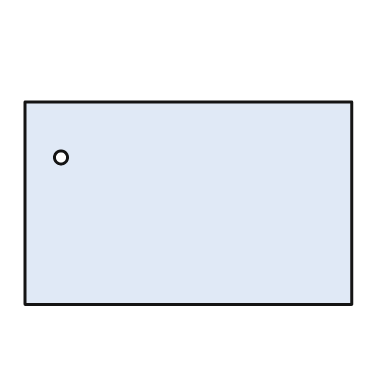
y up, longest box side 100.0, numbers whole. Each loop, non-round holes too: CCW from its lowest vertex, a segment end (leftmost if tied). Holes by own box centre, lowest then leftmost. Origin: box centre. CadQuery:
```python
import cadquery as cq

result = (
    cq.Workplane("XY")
    .moveTo(-50.0, -31.0)
    .lineTo(50.0, -31.0)
    .lineTo(50.0, 31.0)
    .lineTo(-50.0, 31.0)
    .close()
    .moveTo(-39.0, 14.0)
    .circle(2.0)
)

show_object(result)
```